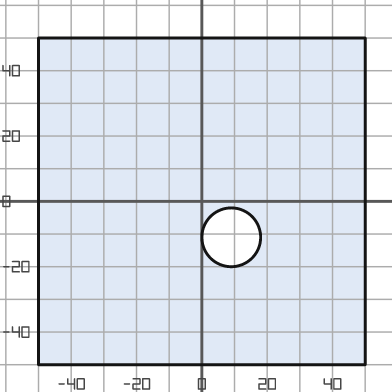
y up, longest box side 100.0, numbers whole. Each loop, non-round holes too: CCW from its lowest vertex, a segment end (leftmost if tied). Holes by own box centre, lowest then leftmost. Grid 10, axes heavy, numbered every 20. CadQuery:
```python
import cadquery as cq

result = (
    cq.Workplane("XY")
    .moveTo(-50.0, -50.0)
    .lineTo(50.0, -50.0)
    .lineTo(50.0, 50.0)
    .lineTo(-50.0, 50.0)
    .close()
    .moveTo(9.0, -11.0)
    .circle(9.0)
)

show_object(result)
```